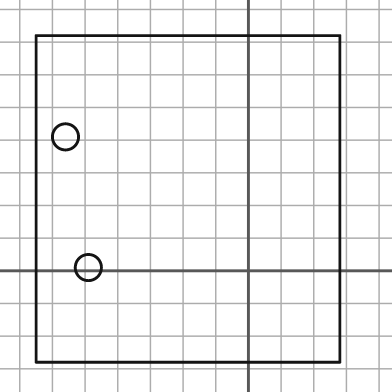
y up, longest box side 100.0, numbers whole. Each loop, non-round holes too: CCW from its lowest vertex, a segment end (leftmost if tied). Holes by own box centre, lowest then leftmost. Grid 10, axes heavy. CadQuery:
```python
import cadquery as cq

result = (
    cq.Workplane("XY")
    .moveTo(-65.0, -28.0)
    .lineTo(28.0, -28.0)
    .lineTo(28.0, 72.0)
    .lineTo(-65.0, 72.0)
    .close()
    .moveTo(-49.0, 1.0)
    .circle(4.0)
    .moveTo(-56.0, 41.0)
    .circle(4.0)
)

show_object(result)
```